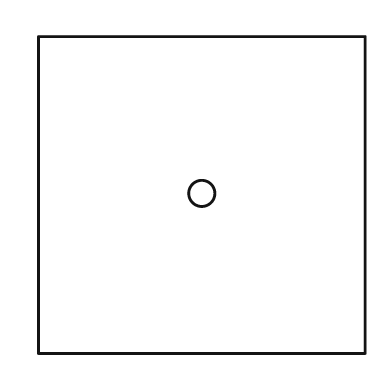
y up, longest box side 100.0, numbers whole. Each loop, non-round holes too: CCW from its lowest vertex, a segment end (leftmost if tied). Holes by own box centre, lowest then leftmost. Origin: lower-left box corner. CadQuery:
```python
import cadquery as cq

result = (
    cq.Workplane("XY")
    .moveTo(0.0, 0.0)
    .lineTo(100.0, 0.0)
    .lineTo(100.0, 97.0)
    .lineTo(0.0, 97.0)
    .close()
    .moveTo(50.0, 49.0)
    .circle(4.0)
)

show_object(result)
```